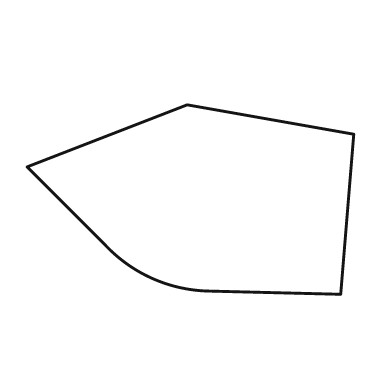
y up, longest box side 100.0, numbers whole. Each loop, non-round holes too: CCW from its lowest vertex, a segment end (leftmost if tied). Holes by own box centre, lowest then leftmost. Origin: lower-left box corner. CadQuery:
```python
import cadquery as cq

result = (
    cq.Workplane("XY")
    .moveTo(96.0, 0.0)
    .lineTo(100.0, 49.0)
    .lineTo(49.0, 58.0)
    .lineTo(0.0, 39.0)
    .lineTo(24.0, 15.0)
    .threePointArc((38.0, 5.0), (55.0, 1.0))
    .close()
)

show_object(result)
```